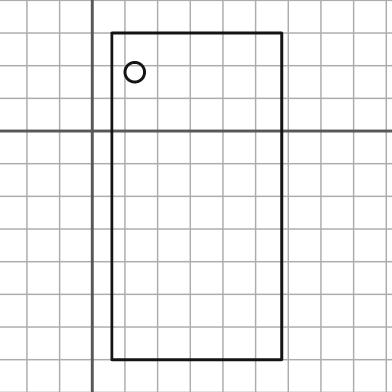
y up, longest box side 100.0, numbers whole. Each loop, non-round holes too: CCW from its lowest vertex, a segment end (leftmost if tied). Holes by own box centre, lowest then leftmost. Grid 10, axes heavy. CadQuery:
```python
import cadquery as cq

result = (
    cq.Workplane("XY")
    .moveTo(6.0, -70.0)
    .lineTo(58.0, -70.0)
    .lineTo(58.0, 30.0)
    .lineTo(6.0, 30.0)
    .close()
    .moveTo(13.0, 18.0)
    .circle(3.0)
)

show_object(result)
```